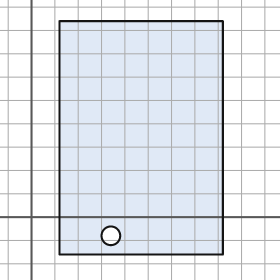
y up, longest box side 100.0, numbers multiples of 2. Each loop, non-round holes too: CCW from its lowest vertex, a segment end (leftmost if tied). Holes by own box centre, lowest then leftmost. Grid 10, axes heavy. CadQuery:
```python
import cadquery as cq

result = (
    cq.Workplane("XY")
    .moveTo(12.0, -16.0)
    .lineTo(82.0, -16.0)
    .lineTo(82.0, 84.0)
    .lineTo(12.0, 84.0)
    .close()
    .moveTo(34.0, -8.0)
    .circle(4.0)
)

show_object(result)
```